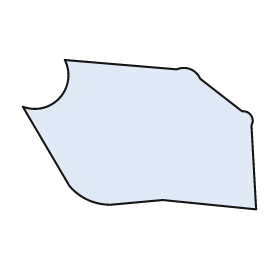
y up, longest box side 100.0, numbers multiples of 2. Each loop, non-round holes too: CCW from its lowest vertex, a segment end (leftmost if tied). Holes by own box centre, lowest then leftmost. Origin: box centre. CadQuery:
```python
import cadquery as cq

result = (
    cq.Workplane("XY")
    .moveTo(50.0, -32.0)
    .lineTo(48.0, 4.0)
    .threePointArc((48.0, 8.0), (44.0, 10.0))
    .lineTo(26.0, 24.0)
    .threePointArc((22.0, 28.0), (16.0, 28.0))
    .lineTo(-32.0, 32.0)
    .threePointArc((-34.0, 16.0), (-50.0, 12.0))
    .lineTo(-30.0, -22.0)
    .threePointArc((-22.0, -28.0), (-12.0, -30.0))
    .lineTo(10.0, -28.0)
    .close()
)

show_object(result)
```